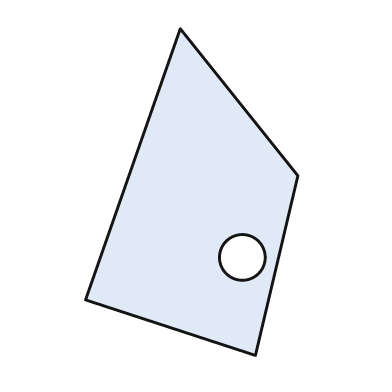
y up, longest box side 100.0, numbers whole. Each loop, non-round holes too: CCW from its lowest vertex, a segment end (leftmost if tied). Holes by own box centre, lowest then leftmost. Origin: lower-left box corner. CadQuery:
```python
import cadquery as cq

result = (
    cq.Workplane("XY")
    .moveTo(52.0, 0.0)
    .lineTo(65.0, 55.0)
    .lineTo(29.0, 100.0)
    .lineTo(0.0, 17.0)
    .close()
    .moveTo(48.0, 30.0)
    .circle(7.0)
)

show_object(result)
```